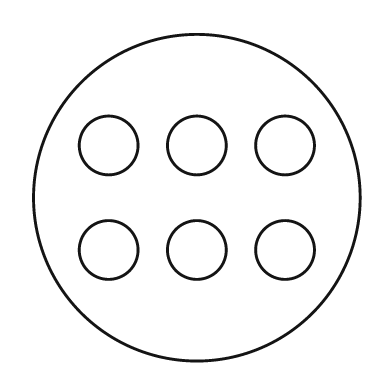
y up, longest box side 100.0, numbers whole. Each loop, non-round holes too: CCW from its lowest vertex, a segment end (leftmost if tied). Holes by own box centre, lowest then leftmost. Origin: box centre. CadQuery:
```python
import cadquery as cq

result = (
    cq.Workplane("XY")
    .moveTo(0.0, 0.0)
    .circle(50.0)
    .moveTo(-27.0, -16.0)
    .circle(9.0)
    .moveTo(0.0, -16.0)
    .circle(9.0)
    .moveTo(27.0, -16.0)
    .circle(9.0)
    .moveTo(-27.0, 16.0)
    .circle(9.0)
    .moveTo(0.0, 16.0)
    .circle(9.0)
    .moveTo(27.0, 16.0)
    .circle(9.0)
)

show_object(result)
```